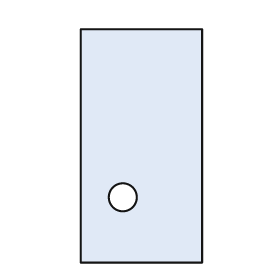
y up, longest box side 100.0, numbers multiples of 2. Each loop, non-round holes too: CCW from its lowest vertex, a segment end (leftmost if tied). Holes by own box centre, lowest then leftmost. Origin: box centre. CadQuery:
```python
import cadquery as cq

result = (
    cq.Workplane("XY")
    .moveTo(-26.0, -50.0)
    .lineTo(26.0, -50.0)
    .lineTo(26.0, 50.0)
    .lineTo(-26.0, 50.0)
    .close()
    .moveTo(-8.0, -22.0)
    .circle(6.0)
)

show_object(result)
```